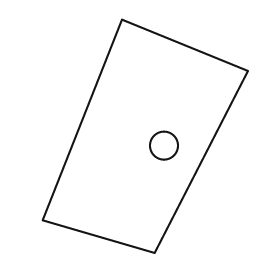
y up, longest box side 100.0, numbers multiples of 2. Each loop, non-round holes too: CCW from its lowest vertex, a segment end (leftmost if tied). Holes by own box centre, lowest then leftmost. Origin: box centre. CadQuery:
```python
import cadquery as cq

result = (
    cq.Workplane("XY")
    .moveTo(4.0, -50.0)
    .lineTo(44.0, 28.0)
    .lineTo(-10.0, 50.0)
    .lineTo(-44.0, -36.0)
    .close()
    .moveTo(8.0, -4.0)
    .circle(6.0)
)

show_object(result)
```